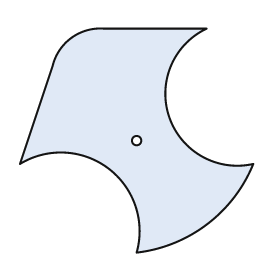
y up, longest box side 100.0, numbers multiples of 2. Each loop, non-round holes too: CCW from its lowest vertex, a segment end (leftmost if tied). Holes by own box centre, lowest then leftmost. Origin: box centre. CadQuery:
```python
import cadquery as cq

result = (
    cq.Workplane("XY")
    .moveTo(0.0, -48.0)
    .threePointArc((30.0, -36.0), (50.0, -10.0))
    .threePointArc((14.0, 10.0), (30.0, 48.0))
    .lineTo(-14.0, 48.0)
    .threePointArc((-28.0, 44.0), (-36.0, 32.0))
    .lineTo(-50.0, -10.0)
    .threePointArc((-12.0, -12.0), (0.0, -48.0))
    .close()
    .moveTo(0.0, 0.0)
    .circle(2.0)
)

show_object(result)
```